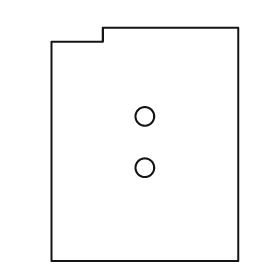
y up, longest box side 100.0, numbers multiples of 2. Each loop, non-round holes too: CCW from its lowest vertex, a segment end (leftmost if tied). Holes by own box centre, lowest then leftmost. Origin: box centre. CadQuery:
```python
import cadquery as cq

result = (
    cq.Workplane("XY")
    .moveTo(-40.0, -50.0)
    .lineTo(40.0, -50.0)
    .lineTo(40.0, 50.0)
    .lineTo(-18.0, 50.0)
    .lineTo(-18.0, 44.0)
    .lineTo(-40.0, 44.0)
    .close()
    .moveTo(0.0, -10.0)
    .circle(4.0)
    .moveTo(0.0, 12.0)
    .circle(4.0)
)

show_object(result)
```